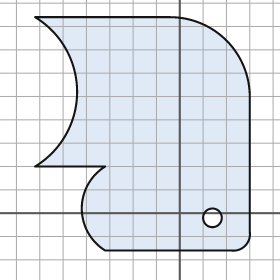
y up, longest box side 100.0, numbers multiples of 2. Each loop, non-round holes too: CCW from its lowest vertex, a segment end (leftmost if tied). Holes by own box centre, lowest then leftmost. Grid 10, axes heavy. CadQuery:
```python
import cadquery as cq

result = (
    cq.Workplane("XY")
    .moveTo(-32.0, -16.0)
    .lineTo(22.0, -16.0)
    .threePointArc((28.0, -14.0), (30.0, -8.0))
    .lineTo(30.0, 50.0)
    .threePointArc((20.0, 74.0), (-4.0, 84.0))
    .lineTo(-62.0, 84.0)
    .threePointArc((-44.0, 52.0), (-62.0, 20.0))
    .lineTo(-32.0, 20.0)
    .threePointArc((-42.0, 2.0), (-32.0, -16.0))
    .close()
    .moveTo(14.0, -2.0)
    .circle(4.0)
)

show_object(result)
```